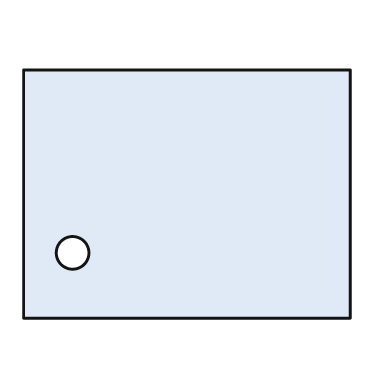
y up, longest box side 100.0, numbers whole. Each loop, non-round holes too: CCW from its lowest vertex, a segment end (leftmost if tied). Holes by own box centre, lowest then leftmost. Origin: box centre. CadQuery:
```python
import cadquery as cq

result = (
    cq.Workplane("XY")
    .moveTo(-50.0, -38.0)
    .lineTo(50.0, -38.0)
    .lineTo(50.0, 38.0)
    .lineTo(-50.0, 38.0)
    .close()
    .moveTo(-35.0, -18.0)
    .circle(5.0)
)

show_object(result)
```